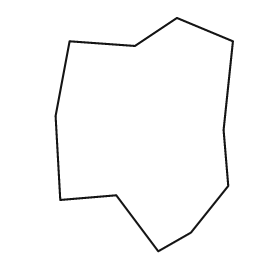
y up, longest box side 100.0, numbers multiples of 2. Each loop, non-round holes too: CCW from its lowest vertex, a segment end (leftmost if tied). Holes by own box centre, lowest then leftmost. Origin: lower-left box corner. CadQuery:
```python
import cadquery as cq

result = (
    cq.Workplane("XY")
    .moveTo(44.0, 0.0)
    .lineTo(58.0, 8.0)
    .lineTo(74.0, 28.0)
    .lineTo(72.0, 52.0)
    .lineTo(76.0, 90.0)
    .lineTo(52.0, 100.0)
    .lineTo(34.0, 88.0)
    .lineTo(6.0, 90.0)
    .lineTo(0.0, 58.0)
    .lineTo(2.0, 22.0)
    .lineTo(26.0, 24.0)
    .close()
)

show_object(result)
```